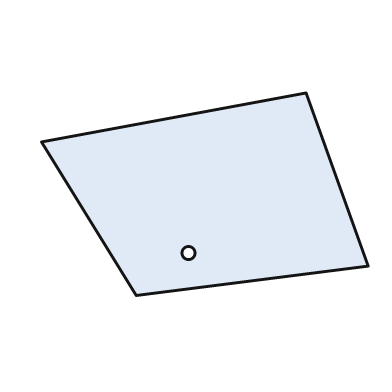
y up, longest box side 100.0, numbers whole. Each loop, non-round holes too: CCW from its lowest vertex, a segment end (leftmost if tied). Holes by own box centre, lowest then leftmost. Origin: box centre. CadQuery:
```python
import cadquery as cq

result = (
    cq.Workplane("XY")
    .moveTo(-21.0, -31.0)
    .lineTo(50.0, -22.0)
    .lineTo(31.0, 31.0)
    .lineTo(-50.0, 16.0)
    .close()
    .moveTo(-5.0, -18.0)
    .circle(2.0)
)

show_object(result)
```